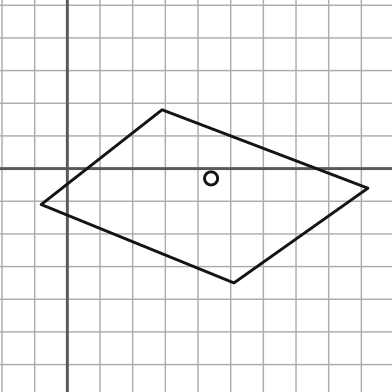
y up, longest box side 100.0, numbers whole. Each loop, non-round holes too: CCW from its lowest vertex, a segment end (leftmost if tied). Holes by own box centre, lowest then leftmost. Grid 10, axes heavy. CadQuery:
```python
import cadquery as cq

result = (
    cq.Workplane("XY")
    .moveTo(51.0, -35.0)
    .lineTo(92.0, -6.0)
    .lineTo(29.0, 18.0)
    .lineTo(-8.0, -11.0)
    .close()
    .moveTo(44.0, -3.0)
    .circle(2.0)
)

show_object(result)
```